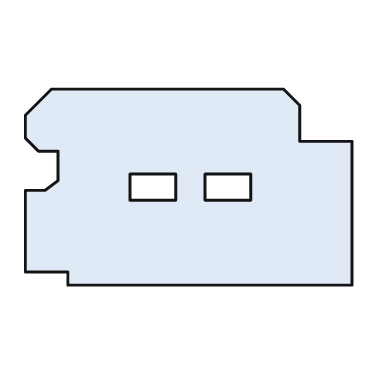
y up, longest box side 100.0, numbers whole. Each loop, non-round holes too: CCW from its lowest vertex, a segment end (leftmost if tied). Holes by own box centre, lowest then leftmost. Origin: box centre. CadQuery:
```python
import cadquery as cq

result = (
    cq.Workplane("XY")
    .moveTo(-37.0, -30.0)
    .lineTo(50.0, -30.0)
    .lineTo(50.0, 14.0)
    .lineTo(34.0, 14.0)
    .lineTo(34.0, 25.0)
    .lineTo(29.0, 30.0)
    .lineTo(-42.0, 30.0)
    .lineTo(-50.0, 22.0)
    .lineTo(-50.0, 15.0)
    .lineTo(-46.0, 11.0)
    .lineTo(-40.0, 11.0)
    .lineTo(-40.0, 2.0)
    .lineTo(-44.0, -1.0)
    .lineTo(-50.0, -1.0)
    .lineTo(-50.0, -26.0)
    .lineTo(-37.0, -26.0)
    .close()
    .moveTo(-18.0, -4.0)
    .lineTo(-4.0, -4.0)
    .lineTo(-4.0, 4.0)
    .lineTo(-18.0, 4.0)
    .close()
    .moveTo(5.0, -4.0)
    .lineTo(19.0, -4.0)
    .lineTo(19.0, 4.0)
    .lineTo(5.0, 4.0)
    .close()
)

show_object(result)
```